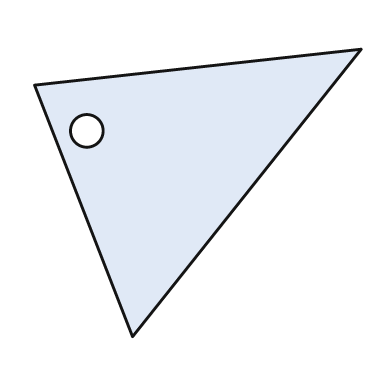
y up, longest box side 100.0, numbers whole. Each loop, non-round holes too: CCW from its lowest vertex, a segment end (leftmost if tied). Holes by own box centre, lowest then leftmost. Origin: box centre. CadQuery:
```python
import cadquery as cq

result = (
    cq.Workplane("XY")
    .moveTo(-20.0, -44.0)
    .lineTo(50.0, 44.0)
    .lineTo(-50.0, 33.0)
    .close()
    .moveTo(-34.0, 19.0)
    .circle(5.0)
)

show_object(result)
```